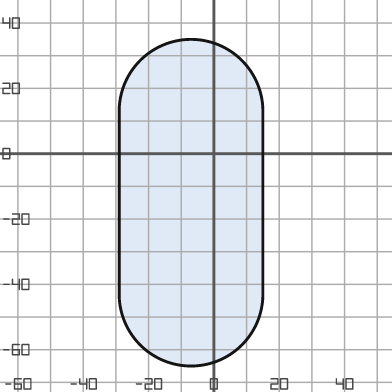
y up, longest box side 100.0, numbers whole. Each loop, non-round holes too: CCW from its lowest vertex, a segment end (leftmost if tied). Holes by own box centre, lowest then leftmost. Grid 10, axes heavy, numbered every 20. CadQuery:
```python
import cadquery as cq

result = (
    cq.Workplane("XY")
    .moveTo(-29.0, -43.0)
    .threePointArc((-7.0, -65.0), (15.0, -43.0))
    .lineTo(15.0, 13.0)
    .threePointArc((-7.0, 35.0), (-29.0, 13.0))
    .close()
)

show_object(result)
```